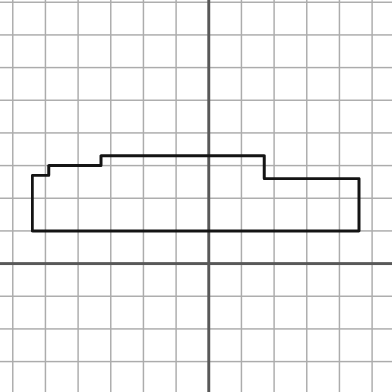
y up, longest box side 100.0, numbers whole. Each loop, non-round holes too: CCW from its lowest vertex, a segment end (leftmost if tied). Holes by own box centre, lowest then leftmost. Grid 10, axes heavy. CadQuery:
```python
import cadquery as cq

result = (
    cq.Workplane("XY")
    .moveTo(-54.0, 10.0)
    .lineTo(46.0, 10.0)
    .lineTo(46.0, 26.0)
    .lineTo(17.0, 26.0)
    .lineTo(17.0, 33.0)
    .lineTo(-33.0, 33.0)
    .lineTo(-33.0, 30.0)
    .lineTo(-49.0, 30.0)
    .lineTo(-49.0, 27.0)
    .lineTo(-54.0, 27.0)
    .close()
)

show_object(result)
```